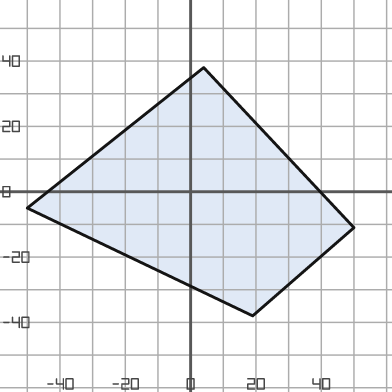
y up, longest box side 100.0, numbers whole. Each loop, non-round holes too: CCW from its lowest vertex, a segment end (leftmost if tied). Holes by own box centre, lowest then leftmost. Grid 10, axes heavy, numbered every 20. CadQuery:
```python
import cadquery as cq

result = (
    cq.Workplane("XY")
    .moveTo(19.0, -38.0)
    .lineTo(50.0, -11.0)
    .lineTo(4.0, 38.0)
    .lineTo(-50.0, -5.0)
    .close()
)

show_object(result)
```